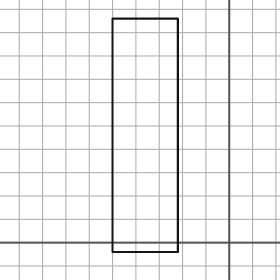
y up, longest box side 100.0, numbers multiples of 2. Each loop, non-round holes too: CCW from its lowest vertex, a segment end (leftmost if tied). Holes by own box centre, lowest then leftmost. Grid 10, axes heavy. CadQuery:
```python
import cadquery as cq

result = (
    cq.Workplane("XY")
    .moveTo(-50.0, -4.0)
    .lineTo(-22.0, -4.0)
    .lineTo(-22.0, 96.0)
    .lineTo(-50.0, 96.0)
    .close()
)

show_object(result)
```